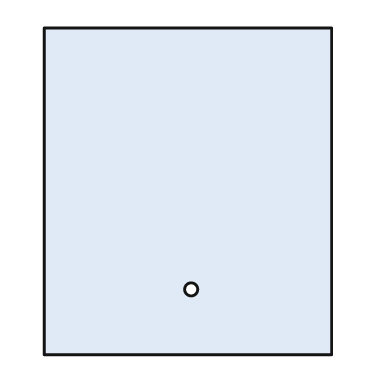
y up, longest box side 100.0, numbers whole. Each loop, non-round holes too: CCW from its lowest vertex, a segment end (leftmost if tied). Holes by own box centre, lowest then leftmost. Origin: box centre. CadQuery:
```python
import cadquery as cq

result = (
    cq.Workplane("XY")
    .moveTo(-44.0, -50.0)
    .lineTo(44.0, -50.0)
    .lineTo(44.0, 50.0)
    .lineTo(-44.0, 50.0)
    .close()
    .moveTo(1.0, -30.0)
    .circle(2.0)
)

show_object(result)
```